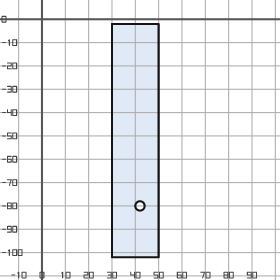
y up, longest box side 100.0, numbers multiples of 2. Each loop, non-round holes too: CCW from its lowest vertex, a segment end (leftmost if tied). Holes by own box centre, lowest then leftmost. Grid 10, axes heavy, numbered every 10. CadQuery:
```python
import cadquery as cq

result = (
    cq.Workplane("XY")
    .moveTo(30.0, -102.0)
    .lineTo(50.0, -102.0)
    .lineTo(50.0, -2.0)
    .lineTo(30.0, -2.0)
    .close()
    .moveTo(42.0, -80.0)
    .circle(2.0)
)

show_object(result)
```